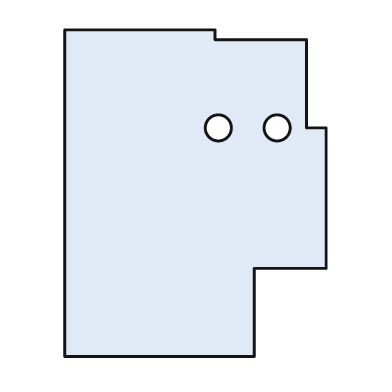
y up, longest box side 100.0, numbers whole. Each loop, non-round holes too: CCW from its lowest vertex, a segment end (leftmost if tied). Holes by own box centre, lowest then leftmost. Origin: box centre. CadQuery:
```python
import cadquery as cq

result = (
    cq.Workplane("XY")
    .moveTo(-40.0, -50.0)
    .lineTo(18.0, -50.0)
    .lineTo(18.0, -23.0)
    .lineTo(40.0, -23.0)
    .lineTo(40.0, 20.0)
    .lineTo(34.0, 20.0)
    .lineTo(34.0, 47.0)
    .lineTo(6.0, 47.0)
    .lineTo(6.0, 50.0)
    .lineTo(-40.0, 50.0)
    .close()
    .moveTo(7.0, 20.0)
    .circle(4.0)
    .moveTo(25.0, 20.0)
    .circle(4.0)
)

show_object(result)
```